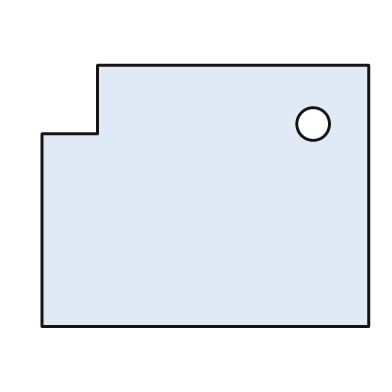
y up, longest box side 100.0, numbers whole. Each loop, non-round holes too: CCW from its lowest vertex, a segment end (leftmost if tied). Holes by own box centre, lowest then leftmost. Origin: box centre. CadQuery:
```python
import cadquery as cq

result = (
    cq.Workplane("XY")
    .moveTo(-50.0, -40.0)
    .lineTo(50.0, -40.0)
    .lineTo(50.0, 40.0)
    .lineTo(-33.0, 40.0)
    .lineTo(-33.0, 19.0)
    .lineTo(-50.0, 19.0)
    .close()
    .moveTo(33.0, 22.0)
    .circle(5.0)
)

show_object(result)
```